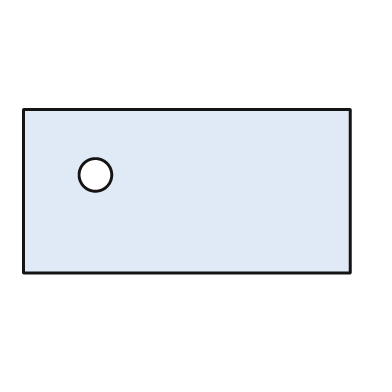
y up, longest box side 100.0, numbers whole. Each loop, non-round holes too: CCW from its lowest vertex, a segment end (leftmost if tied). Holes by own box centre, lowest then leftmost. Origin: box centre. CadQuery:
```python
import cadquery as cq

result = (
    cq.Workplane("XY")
    .moveTo(-50.0, -25.0)
    .lineTo(50.0, -25.0)
    .lineTo(50.0, 25.0)
    .lineTo(-50.0, 25.0)
    .close()
    .moveTo(-28.0, 5.0)
    .circle(5.0)
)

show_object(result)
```